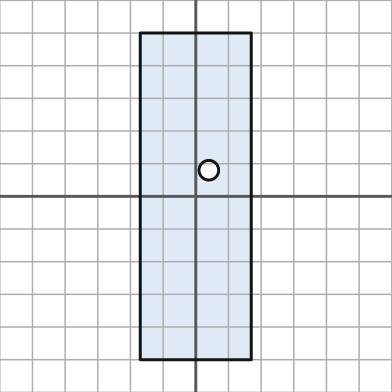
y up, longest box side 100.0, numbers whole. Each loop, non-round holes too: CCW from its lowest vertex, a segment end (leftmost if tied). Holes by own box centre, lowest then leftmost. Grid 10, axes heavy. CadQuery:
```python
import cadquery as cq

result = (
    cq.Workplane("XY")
    .moveTo(-17.0, -50.0)
    .lineTo(17.0, -50.0)
    .lineTo(17.0, 50.0)
    .lineTo(-17.0, 50.0)
    .close()
    .moveTo(4.0, 8.0)
    .circle(3.0)
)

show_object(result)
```